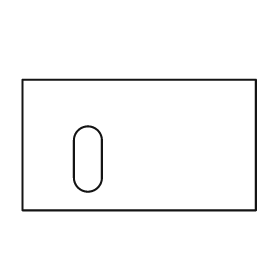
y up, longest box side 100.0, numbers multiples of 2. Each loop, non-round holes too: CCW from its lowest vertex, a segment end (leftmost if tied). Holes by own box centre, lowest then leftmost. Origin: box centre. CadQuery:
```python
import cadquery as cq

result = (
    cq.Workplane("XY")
    .moveTo(-50.0, -28.0)
    .lineTo(50.0, -28.0)
    .lineTo(50.0, 28.0)
    .lineTo(-50.0, 28.0)
    .close()
    .moveTo(-28.0, -14.0)
    .threePointArc((-22.0, -20.0), (-16.0, -14.0))
    .lineTo(-16.0, 2.0)
    .threePointArc((-22.0, 8.0), (-28.0, 2.0))
    .close()
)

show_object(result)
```